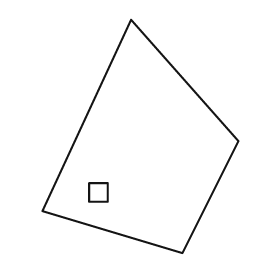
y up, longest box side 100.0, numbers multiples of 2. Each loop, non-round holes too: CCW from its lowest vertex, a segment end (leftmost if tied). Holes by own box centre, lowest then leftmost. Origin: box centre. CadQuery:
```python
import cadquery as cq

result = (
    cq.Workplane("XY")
    .moveTo(18.0, -50.0)
    .lineTo(42.0, -2.0)
    .lineTo(-4.0, 50.0)
    .lineTo(-42.0, -32.0)
    .close()
    .moveTo(-22.0, -28.0)
    .lineTo(-14.0, -28.0)
    .lineTo(-14.0, -20.0)
    .lineTo(-22.0, -20.0)
    .close()
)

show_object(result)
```